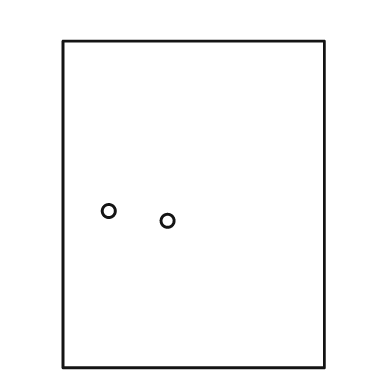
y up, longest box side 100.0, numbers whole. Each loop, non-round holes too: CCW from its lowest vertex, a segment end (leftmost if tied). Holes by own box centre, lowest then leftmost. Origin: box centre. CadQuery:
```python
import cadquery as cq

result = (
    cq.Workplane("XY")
    .moveTo(-40.0, -50.0)
    .lineTo(40.0, -50.0)
    .lineTo(40.0, 50.0)
    .lineTo(-40.0, 50.0)
    .close()
    .moveTo(-8.0, -5.0)
    .circle(2.0)
    .moveTo(-26.0, -2.0)
    .circle(2.0)
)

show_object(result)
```